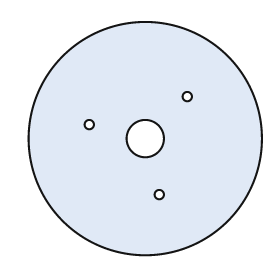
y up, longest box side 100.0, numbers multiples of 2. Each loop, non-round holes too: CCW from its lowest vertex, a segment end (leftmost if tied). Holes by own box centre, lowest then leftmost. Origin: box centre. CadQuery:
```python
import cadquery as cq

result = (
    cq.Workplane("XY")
    .moveTo(0.0, 0.0)
    .circle(50.0)
    .moveTo(6.0, -24.0)
    .circle(2.0)
    .moveTo(0.0, 0.0)
    .circle(8.0)
    .moveTo(-24.0, 6.0)
    .circle(2.0)
    .moveTo(18.0, 18.0)
    .circle(2.0)
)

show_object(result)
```